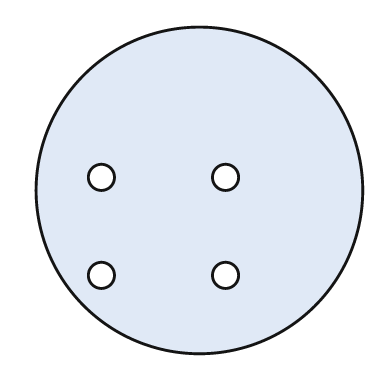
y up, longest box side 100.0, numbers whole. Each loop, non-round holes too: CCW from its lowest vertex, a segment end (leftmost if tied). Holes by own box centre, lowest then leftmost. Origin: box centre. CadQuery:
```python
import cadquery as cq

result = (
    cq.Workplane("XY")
    .moveTo(0.0, 0.0)
    .circle(50.0)
    .moveTo(-30.0, -26.0)
    .circle(4.0)
    .moveTo(8.0, -26.0)
    .circle(4.0)
    .moveTo(-30.0, 4.0)
    .circle(4.0)
    .moveTo(8.0, 4.0)
    .circle(4.0)
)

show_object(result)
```